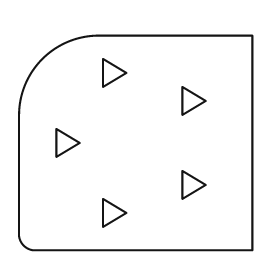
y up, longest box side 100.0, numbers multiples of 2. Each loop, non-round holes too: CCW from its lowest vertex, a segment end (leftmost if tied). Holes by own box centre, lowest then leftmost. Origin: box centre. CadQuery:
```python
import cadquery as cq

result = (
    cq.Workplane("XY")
    .moveTo(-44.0, -46.0)
    .lineTo(50.0, -46.0)
    .lineTo(50.0, 46.0)
    .lineTo(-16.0, 46.0)
    .threePointArc((-40.0, 36.0), (-50.0, 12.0))
    .lineTo(-50.0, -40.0)
    .threePointArc((-48.0, -44.0), (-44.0, -46.0))
    .close()
    .moveTo(-14.0, -36.0)
    .lineTo(-4.0, -30.0)
    .lineTo(-14.0, -24.0)
    .close()
    .moveTo(20.0, -24.0)
    .lineTo(30.0, -18.0)
    .lineTo(20.0, -12.0)
    .close()
    .moveTo(-34.0, -6.0)
    .lineTo(-24.0, 0.0)
    .lineTo(-34.0, 6.0)
    .close()
    .moveTo(20.0, 12.0)
    .lineTo(30.0, 18.0)
    .lineTo(20.0, 24.0)
    .close()
    .moveTo(-14.0, 24.0)
    .lineTo(-4.0, 30.0)
    .lineTo(-14.0, 36.0)
    .close()
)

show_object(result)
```